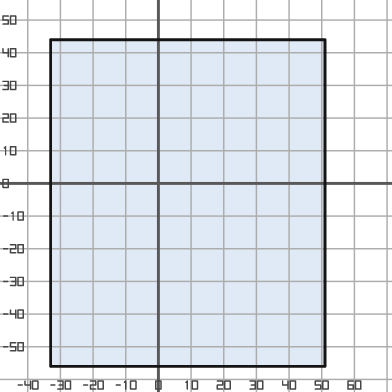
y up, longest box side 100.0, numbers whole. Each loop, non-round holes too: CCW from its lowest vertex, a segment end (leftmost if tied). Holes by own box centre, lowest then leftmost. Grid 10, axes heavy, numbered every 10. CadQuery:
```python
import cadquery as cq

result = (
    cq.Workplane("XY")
    .moveTo(-33.0, -56.0)
    .lineTo(51.0, -56.0)
    .lineTo(51.0, 44.0)
    .lineTo(-33.0, 44.0)
    .close()
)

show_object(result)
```